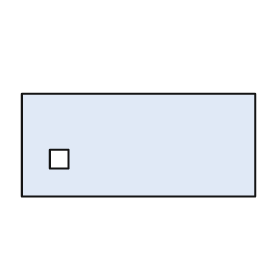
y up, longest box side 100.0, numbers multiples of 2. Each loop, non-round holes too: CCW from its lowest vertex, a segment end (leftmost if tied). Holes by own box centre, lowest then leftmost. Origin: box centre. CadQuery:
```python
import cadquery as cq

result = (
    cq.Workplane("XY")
    .moveTo(-50.0, -22.0)
    .lineTo(50.0, -22.0)
    .lineTo(50.0, 22.0)
    .lineTo(-50.0, 22.0)
    .close()
    .moveTo(-38.0, -10.0)
    .lineTo(-30.0, -10.0)
    .lineTo(-30.0, -2.0)
    .lineTo(-38.0, -2.0)
    .close()
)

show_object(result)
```